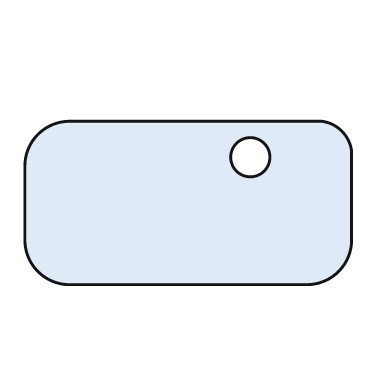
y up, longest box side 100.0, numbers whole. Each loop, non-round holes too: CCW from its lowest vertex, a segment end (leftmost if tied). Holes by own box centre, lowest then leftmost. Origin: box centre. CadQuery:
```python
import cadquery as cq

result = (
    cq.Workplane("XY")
    .moveTo(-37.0, -25.0)
    .lineTo(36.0, -25.0)
    .threePointArc((46.0, -21.0), (50.0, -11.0))
    .lineTo(50.0, 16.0)
    .threePointArc((47.0, 22.0), (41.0, 25.0))
    .lineTo(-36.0, 25.0)
    .threePointArc((-46.0, 21.0), (-50.0, 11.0))
    .lineTo(-50.0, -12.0)
    .threePointArc((-46.0, -21.0), (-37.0, -25.0))
    .close()
    .moveTo(19.0, 14.0)
    .circle(6.0)
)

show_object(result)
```